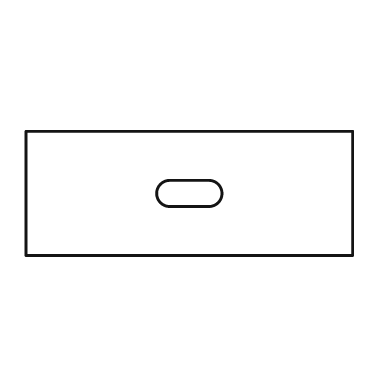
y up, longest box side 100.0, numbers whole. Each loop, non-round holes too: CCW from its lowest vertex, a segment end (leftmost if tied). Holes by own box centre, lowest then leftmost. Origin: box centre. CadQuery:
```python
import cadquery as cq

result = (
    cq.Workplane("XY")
    .moveTo(-50.0, -19.0)
    .lineTo(50.0, -19.0)
    .lineTo(50.0, 19.0)
    .lineTo(-50.0, 19.0)
    .close()
    .moveTo(-6.0, -4.0)
    .lineTo(6.0, -4.0)
    .threePointArc((10.0, 0.0), (6.0, 4.0))
    .lineTo(-6.0, 4.0)
    .threePointArc((-10.0, 0.0), (-6.0, -4.0))
    .close()
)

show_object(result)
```